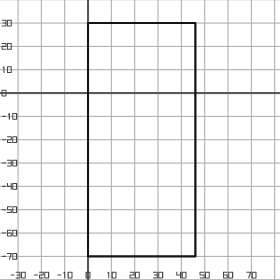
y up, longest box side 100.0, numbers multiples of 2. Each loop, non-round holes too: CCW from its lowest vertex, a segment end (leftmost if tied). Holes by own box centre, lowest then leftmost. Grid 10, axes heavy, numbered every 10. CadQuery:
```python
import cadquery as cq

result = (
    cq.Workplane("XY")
    .moveTo(0.0, -70.0)
    .lineTo(46.0, -70.0)
    .lineTo(46.0, 30.0)
    .lineTo(0.0, 30.0)
    .close()
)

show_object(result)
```